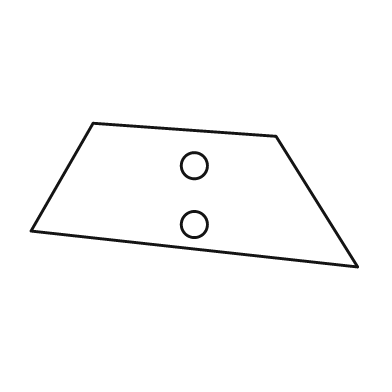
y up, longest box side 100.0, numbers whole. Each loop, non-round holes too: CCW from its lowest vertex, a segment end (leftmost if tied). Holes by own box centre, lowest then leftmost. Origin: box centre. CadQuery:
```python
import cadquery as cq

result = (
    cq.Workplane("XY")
    .moveTo(50.0, -22.0)
    .lineTo(25.0, 18.0)
    .lineTo(-31.0, 22.0)
    .lineTo(-50.0, -11.0)
    .close()
    .moveTo(0.0, -9.0)
    .circle(4.0)
    .moveTo(0.0, 9.0)
    .circle(4.0)
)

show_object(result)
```